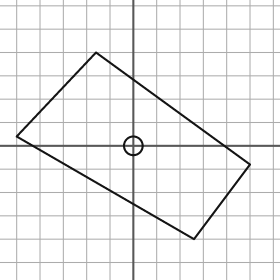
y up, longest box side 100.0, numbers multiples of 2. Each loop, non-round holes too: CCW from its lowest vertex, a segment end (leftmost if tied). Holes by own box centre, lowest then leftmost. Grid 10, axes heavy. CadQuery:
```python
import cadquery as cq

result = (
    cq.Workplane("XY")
    .moveTo(26.0, -40.0)
    .lineTo(50.0, -8.0)
    .lineTo(-16.0, 40.0)
    .lineTo(-50.0, 4.0)
    .close()
    .moveTo(0.0, 0.0)
    .circle(4.0)
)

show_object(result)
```